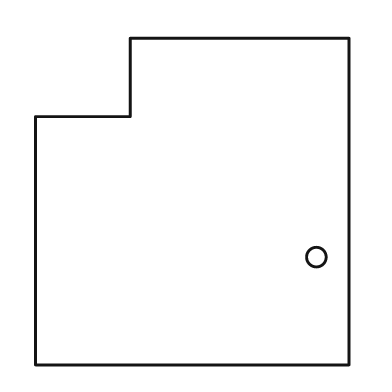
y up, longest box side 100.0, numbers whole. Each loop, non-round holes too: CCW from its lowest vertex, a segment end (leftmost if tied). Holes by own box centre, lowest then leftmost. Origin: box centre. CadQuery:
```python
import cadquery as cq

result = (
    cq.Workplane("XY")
    .moveTo(-48.0, -50.0)
    .lineTo(48.0, -50.0)
    .lineTo(48.0, 50.0)
    .lineTo(-19.0, 50.0)
    .lineTo(-19.0, 26.0)
    .lineTo(-48.0, 26.0)
    .close()
    .moveTo(38.0, -17.0)
    .circle(3.0)
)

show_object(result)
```